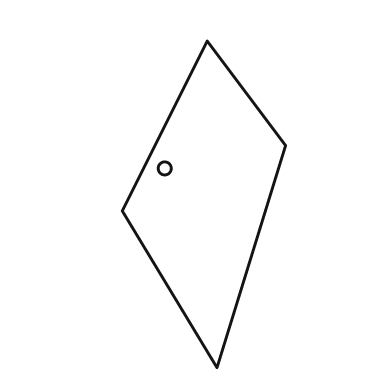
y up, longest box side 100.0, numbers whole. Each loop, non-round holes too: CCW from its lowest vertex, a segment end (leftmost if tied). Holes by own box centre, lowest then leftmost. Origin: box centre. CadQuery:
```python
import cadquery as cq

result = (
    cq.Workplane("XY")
    .moveTo(4.0, -50.0)
    .lineTo(25.0, 18.0)
    .lineTo(1.0, 50.0)
    .lineTo(-25.0, -2.0)
    .close()
    .moveTo(-12.0, 11.0)
    .circle(2.0)
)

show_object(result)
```